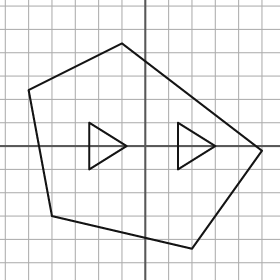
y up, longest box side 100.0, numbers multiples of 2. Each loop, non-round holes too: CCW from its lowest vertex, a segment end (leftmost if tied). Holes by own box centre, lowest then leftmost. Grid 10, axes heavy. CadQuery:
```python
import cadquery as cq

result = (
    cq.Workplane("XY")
    .moveTo(20.0, -44.0)
    .lineTo(50.0, -2.0)
    .lineTo(-10.0, 44.0)
    .lineTo(-50.0, 24.0)
    .lineTo(-40.0, -30.0)
    .close()
    .moveTo(-24.0, -10.0)
    .lineTo(-8.0, 0.0)
    .lineTo(-24.0, 10.0)
    .close()
    .moveTo(14.0, -10.0)
    .lineTo(30.0, 0.0)
    .lineTo(14.0, 10.0)
    .close()
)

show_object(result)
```